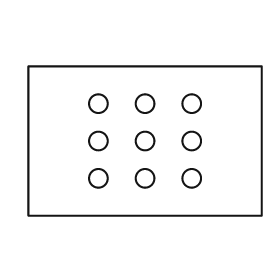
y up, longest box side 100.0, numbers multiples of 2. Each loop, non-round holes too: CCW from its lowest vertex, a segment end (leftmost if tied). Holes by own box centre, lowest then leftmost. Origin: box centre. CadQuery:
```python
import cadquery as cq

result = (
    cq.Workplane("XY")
    .moveTo(-50.0, -32.0)
    .lineTo(50.0, -32.0)
    .lineTo(50.0, 32.0)
    .lineTo(-50.0, 32.0)
    .close()
    .moveTo(-20.0, -16.0)
    .circle(4.0)
    .moveTo(0.0, -16.0)
    .circle(4.0)
    .moveTo(20.0, -16.0)
    .circle(4.0)
    .moveTo(-20.0, 0.0)
    .circle(4.0)
    .moveTo(0.0, 0.0)
    .circle(4.0)
    .moveTo(20.0, 0.0)
    .circle(4.0)
    .moveTo(-20.0, 16.0)
    .circle(4.0)
    .moveTo(0.0, 16.0)
    .circle(4.0)
    .moveTo(20.0, 16.0)
    .circle(4.0)
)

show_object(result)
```